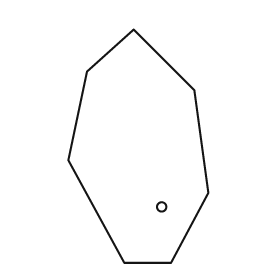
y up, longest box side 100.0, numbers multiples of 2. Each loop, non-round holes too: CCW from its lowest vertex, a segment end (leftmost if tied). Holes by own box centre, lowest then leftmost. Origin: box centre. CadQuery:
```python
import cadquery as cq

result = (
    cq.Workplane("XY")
    .moveTo(-6.0, -50.0)
    .lineTo(14.0, -50.0)
    .lineTo(30.0, -20.0)
    .lineTo(24.0, 24.0)
    .lineTo(-2.0, 50.0)
    .lineTo(-22.0, 32.0)
    .lineTo(-30.0, -6.0)
    .close()
    .moveTo(10.0, -26.0)
    .circle(2.0)
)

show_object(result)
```